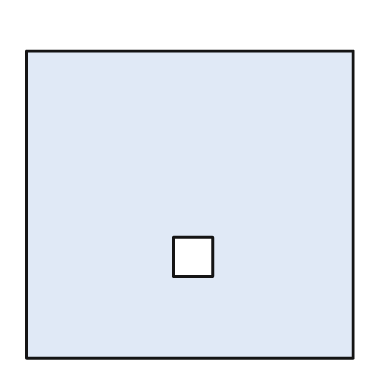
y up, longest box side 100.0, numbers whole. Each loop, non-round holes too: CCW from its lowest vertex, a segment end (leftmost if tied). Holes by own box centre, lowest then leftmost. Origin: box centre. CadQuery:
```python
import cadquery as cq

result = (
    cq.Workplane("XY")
    .moveTo(-50.0, -47.0)
    .lineTo(50.0, -47.0)
    .lineTo(50.0, 47.0)
    .lineTo(-50.0, 47.0)
    .close()
    .moveTo(-5.0, -22.0)
    .lineTo(7.0, -22.0)
    .lineTo(7.0, -10.0)
    .lineTo(-5.0, -10.0)
    .close()
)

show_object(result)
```